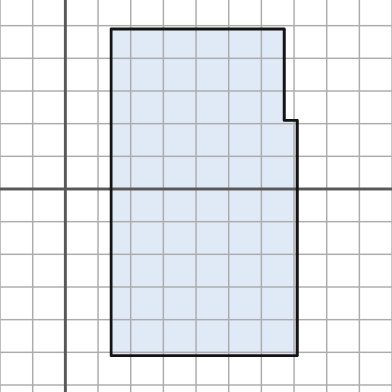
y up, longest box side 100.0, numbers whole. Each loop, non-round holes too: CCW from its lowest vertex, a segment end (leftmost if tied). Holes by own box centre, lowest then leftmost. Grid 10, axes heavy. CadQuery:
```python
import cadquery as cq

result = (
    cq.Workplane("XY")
    .moveTo(14.0, -51.0)
    .lineTo(71.0, -51.0)
    .lineTo(71.0, 21.0)
    .lineTo(67.0, 21.0)
    .lineTo(67.0, 49.0)
    .lineTo(14.0, 49.0)
    .close()
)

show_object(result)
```